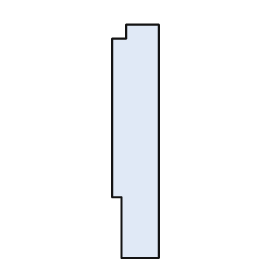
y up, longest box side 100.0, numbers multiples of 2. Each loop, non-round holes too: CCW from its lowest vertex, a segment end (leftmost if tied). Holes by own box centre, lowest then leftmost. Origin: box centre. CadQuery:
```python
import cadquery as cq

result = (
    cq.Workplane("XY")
    .moveTo(-6.0, -50.0)
    .lineTo(10.0, -50.0)
    .lineTo(10.0, 50.0)
    .lineTo(-4.0, 50.0)
    .lineTo(-4.0, 44.0)
    .lineTo(-10.0, 44.0)
    .lineTo(-10.0, -24.0)
    .lineTo(-6.0, -24.0)
    .close()
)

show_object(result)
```